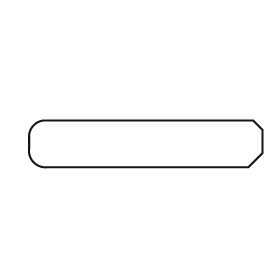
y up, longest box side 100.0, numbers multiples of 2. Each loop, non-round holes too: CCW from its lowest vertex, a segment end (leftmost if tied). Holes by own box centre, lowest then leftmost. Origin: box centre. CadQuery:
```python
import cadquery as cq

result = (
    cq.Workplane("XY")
    .moveTo(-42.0, -10.0)
    .lineTo(44.0, -10.0)
    .lineTo(50.0, -4.0)
    .lineTo(50.0, 6.0)
    .lineTo(46.0, 10.0)
    .lineTo(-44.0, 10.0)
    .threePointArc((-48.0, 8.0), (-50.0, 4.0))
    .lineTo(-50.0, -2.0)
    .threePointArc((-48.0, -8.0), (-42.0, -10.0))
    .close()
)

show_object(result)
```